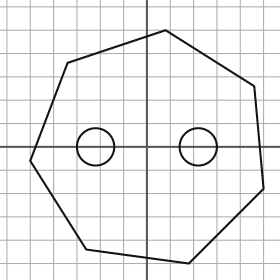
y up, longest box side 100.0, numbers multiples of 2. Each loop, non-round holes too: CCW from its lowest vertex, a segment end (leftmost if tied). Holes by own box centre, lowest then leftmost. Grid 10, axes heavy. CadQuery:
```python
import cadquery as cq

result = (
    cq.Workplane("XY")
    .moveTo(18.0, -50.0)
    .lineTo(50.0, -18.0)
    .lineTo(46.0, 26.0)
    .lineTo(8.0, 50.0)
    .lineTo(-34.0, 36.0)
    .lineTo(-50.0, -6.0)
    .lineTo(-26.0, -44.0)
    .close()
    .moveTo(-22.0, 0.0)
    .circle(8.0)
    .moveTo(22.0, 0.0)
    .circle(8.0)
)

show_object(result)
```